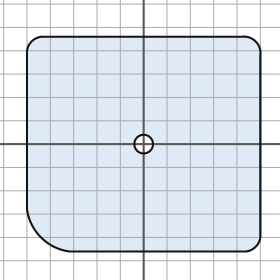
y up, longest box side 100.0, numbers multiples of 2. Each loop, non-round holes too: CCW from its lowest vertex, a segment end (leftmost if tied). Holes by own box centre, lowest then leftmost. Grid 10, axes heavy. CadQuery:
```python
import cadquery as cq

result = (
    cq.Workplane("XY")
    .moveTo(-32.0, -46.0)
    .lineTo(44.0, -46.0)
    .threePointArc((48.0, -44.0), (50.0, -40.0))
    .lineTo(50.0, 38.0)
    .threePointArc((48.0, 44.0), (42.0, 46.0))
    .lineTo(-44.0, 46.0)
    .threePointArc((-48.0, 44.0), (-50.0, 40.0))
    .lineTo(-50.0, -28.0)
    .threePointArc((-44.0, -40.0), (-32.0, -46.0))
    .close()
    .moveTo(0.0, 0.0)
    .circle(4.0)
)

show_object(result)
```